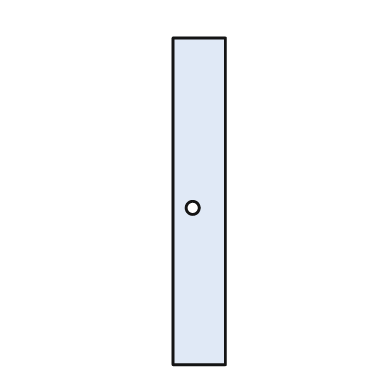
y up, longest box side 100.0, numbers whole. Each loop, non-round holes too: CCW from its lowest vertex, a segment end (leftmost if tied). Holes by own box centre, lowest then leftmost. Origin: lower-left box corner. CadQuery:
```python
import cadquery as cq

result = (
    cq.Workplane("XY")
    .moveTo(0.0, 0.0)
    .lineTo(16.0, 0.0)
    .lineTo(16.0, 100.0)
    .lineTo(0.0, 100.0)
    .close()
    .moveTo(6.0, 48.0)
    .circle(2.0)
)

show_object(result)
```